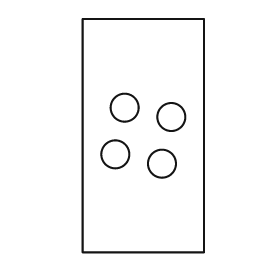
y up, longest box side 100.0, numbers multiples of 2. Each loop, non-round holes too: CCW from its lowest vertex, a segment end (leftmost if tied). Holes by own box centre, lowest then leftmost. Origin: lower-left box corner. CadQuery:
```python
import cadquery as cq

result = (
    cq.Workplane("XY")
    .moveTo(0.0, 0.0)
    .lineTo(52.0, 0.0)
    .lineTo(52.0, 100.0)
    .lineTo(0.0, 100.0)
    .close()
    .moveTo(34.0, 38.0)
    .circle(6.0)
    .moveTo(14.0, 42.0)
    .circle(6.0)
    .moveTo(38.0, 58.0)
    .circle(6.0)
    .moveTo(18.0, 62.0)
    .circle(6.0)
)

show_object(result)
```